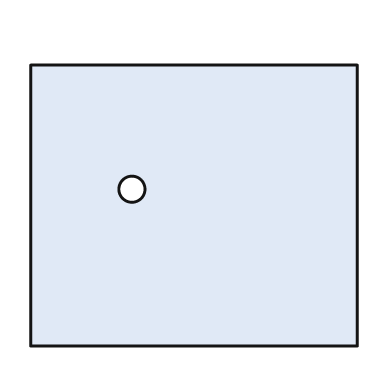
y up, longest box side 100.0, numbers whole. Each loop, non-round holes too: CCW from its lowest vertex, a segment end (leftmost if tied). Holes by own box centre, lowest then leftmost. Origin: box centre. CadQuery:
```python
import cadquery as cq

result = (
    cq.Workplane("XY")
    .moveTo(-50.0, -43.0)
    .lineTo(50.0, -43.0)
    .lineTo(50.0, 43.0)
    .lineTo(-50.0, 43.0)
    .close()
    .moveTo(-19.0, 5.0)
    .circle(4.0)
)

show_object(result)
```